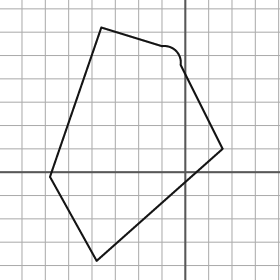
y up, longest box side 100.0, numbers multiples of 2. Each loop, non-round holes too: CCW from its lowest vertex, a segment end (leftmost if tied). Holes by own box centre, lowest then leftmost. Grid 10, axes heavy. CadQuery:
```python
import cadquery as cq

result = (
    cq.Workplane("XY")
    .moveTo(-38.0, -38.0)
    .lineTo(16.0, 10.0)
    .lineTo(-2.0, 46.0)
    .threePointArc((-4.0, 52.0), (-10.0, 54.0))
    .lineTo(-36.0, 62.0)
    .lineTo(-58.0, -2.0)
    .close()
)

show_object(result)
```